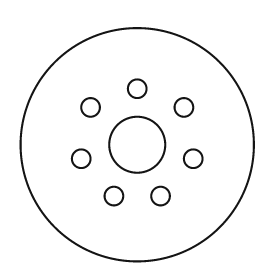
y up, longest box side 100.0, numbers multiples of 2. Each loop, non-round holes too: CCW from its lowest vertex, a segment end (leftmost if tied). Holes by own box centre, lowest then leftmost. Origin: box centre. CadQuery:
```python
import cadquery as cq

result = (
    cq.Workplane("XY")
    .moveTo(0.0, 0.0)
    .circle(50.0)
    .moveTo(-10.0, -22.0)
    .circle(4.0)
    .moveTo(10.0, -22.0)
    .circle(4.0)
    .moveTo(-24.0, -6.0)
    .circle(4.0)
    .moveTo(24.0, -6.0)
    .circle(4.0)
    .moveTo(0.0, 0.0)
    .circle(12.0)
    .moveTo(-20.0, 16.0)
    .circle(4.0)
    .moveTo(20.0, 16.0)
    .circle(4.0)
    .moveTo(0.0, 24.0)
    .circle(4.0)
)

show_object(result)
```